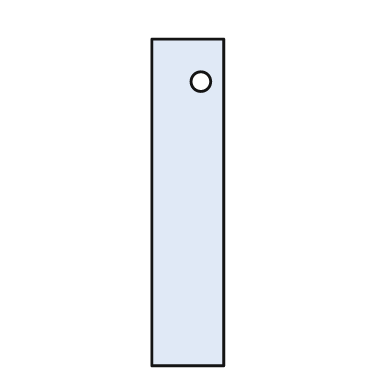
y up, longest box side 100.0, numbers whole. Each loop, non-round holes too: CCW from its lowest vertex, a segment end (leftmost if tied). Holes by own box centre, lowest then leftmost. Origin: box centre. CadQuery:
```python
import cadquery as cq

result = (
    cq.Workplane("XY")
    .moveTo(-11.0, -50.0)
    .lineTo(11.0, -50.0)
    .lineTo(11.0, 50.0)
    .lineTo(-11.0, 50.0)
    .close()
    .moveTo(4.0, 37.0)
    .circle(3.0)
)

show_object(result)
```